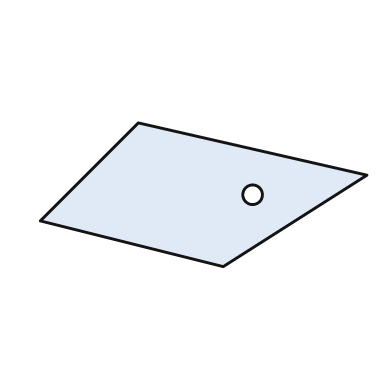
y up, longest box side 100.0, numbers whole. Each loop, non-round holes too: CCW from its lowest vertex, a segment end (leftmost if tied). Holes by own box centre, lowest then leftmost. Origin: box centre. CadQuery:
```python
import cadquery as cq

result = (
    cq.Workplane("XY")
    .moveTo(6.0, -22.0)
    .lineTo(50.0, 6.0)
    .lineTo(-20.0, 22.0)
    .lineTo(-50.0, -8.0)
    .close()
    .moveTo(15.0, 0.0)
    .circle(3.0)
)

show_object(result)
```